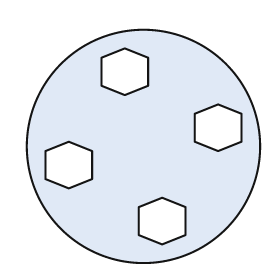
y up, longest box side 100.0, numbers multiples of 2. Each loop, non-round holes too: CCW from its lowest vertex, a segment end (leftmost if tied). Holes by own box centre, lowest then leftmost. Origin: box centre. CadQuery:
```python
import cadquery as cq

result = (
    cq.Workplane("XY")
    .moveTo(0.0, 0.0)
    .circle(50.0)
    .moveTo(8.0, -42.0)
    .lineTo(18.0, -38.0)
    .lineTo(18.0, -26.0)
    .lineTo(8.0, -22.0)
    .lineTo(-2.0, -26.0)
    .lineTo(-2.0, -38.0)
    .close()
    .moveTo(-32.0, -18.0)
    .lineTo(-22.0, -14.0)
    .lineTo(-22.0, -2.0)
    .lineTo(-32.0, 2.0)
    .lineTo(-42.0, -2.0)
    .lineTo(-42.0, -14.0)
    .close()
    .moveTo(32.0, -2.0)
    .lineTo(42.0, 2.0)
    .lineTo(42.0, 14.0)
    .lineTo(32.0, 18.0)
    .lineTo(22.0, 14.0)
    .lineTo(22.0, 2.0)
    .close()
    .moveTo(-8.0, 22.0)
    .lineTo(2.0, 26.0)
    .lineTo(2.0, 38.0)
    .lineTo(-8.0, 42.0)
    .lineTo(-18.0, 38.0)
    .lineTo(-18.0, 26.0)
    .close()
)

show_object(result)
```